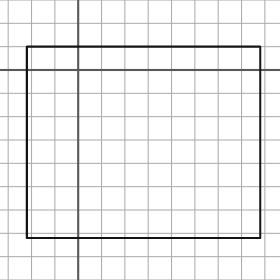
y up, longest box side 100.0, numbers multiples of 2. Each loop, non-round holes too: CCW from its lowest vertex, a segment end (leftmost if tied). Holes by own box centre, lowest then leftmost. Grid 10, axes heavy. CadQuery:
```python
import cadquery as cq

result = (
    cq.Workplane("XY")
    .moveTo(-22.0, -72.0)
    .lineTo(78.0, -72.0)
    .lineTo(78.0, 10.0)
    .lineTo(-22.0, 10.0)
    .close()
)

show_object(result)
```